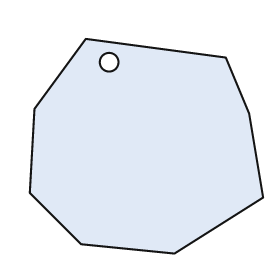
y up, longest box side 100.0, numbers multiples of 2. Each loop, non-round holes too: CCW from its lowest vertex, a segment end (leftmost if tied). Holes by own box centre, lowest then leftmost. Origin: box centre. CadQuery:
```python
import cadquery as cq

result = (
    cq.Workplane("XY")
    .moveTo(12.0, -46.0)
    .lineTo(50.0, -22.0)
    .lineTo(44.0, 14.0)
    .lineTo(34.0, 38.0)
    .lineTo(-26.0, 46.0)
    .lineTo(-48.0, 16.0)
    .lineTo(-50.0, -20.0)
    .lineTo(-28.0, -42.0)
    .close()
    .moveTo(-16.0, 36.0)
    .circle(4.0)
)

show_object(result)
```